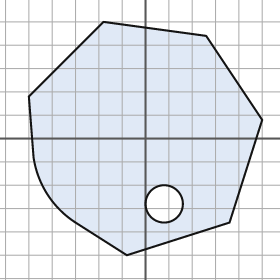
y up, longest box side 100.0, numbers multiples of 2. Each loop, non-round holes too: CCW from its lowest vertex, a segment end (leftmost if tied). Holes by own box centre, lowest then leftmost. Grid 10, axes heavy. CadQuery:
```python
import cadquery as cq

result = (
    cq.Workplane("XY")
    .moveTo(-8.0, -50.0)
    .lineTo(36.0, -36.0)
    .lineTo(50.0, 8.0)
    .lineTo(26.0, 44.0)
    .lineTo(-18.0, 50.0)
    .lineTo(-50.0, 18.0)
    .lineTo(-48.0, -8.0)
    .threePointArc((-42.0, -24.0), (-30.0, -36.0))
    .close()
    .moveTo(8.0, -28.0)
    .circle(8.0)
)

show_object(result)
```